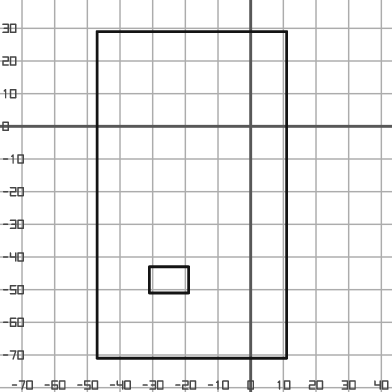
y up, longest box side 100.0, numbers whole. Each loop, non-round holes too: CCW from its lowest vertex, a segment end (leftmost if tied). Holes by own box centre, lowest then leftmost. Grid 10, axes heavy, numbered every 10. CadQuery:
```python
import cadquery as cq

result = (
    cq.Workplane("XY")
    .moveTo(-47.0, -71.0)
    .lineTo(11.0, -71.0)
    .lineTo(11.0, 29.0)
    .lineTo(-47.0, 29.0)
    .close()
    .moveTo(-31.0, -51.0)
    .lineTo(-19.0, -51.0)
    .lineTo(-19.0, -43.0)
    .lineTo(-31.0, -43.0)
    .close()
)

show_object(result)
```